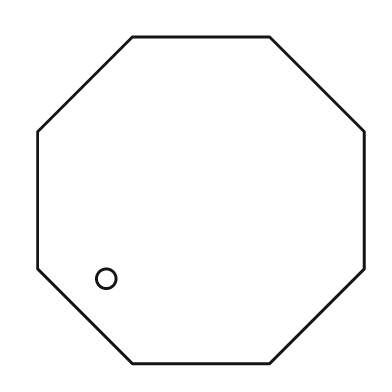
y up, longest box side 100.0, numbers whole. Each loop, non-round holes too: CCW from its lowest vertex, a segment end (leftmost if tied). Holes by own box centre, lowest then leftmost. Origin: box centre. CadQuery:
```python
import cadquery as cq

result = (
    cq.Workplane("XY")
    .moveTo(-21.0, -50.0)
    .lineTo(21.0, -50.0)
    .lineTo(50.0, -21.0)
    .lineTo(50.0, 21.0)
    .lineTo(21.0, 50.0)
    .lineTo(-21.0, 50.0)
    .lineTo(-50.0, 21.0)
    .lineTo(-50.0, -21.0)
    .close()
    .moveTo(-29.0, -24.0)
    .circle(3.0)
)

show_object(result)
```